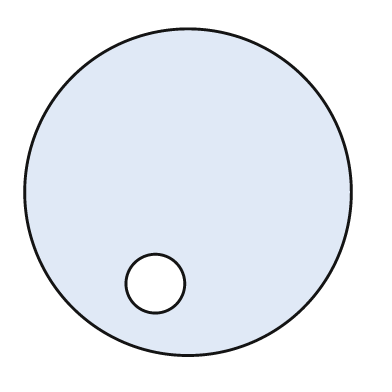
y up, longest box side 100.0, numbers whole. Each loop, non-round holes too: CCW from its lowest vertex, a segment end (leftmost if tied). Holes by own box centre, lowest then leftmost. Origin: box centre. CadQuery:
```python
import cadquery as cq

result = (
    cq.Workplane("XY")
    .moveTo(0.0, 0.0)
    .circle(50.0)
    .moveTo(-10.0, -28.0)
    .circle(9.0)
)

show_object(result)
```